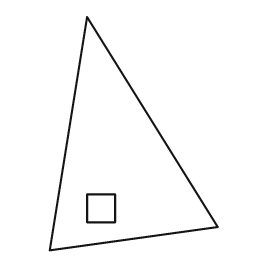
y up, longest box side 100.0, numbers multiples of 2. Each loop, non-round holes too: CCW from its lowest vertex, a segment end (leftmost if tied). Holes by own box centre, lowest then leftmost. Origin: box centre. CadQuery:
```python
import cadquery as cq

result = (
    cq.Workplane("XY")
    .moveTo(-36.0, -50.0)
    .lineTo(36.0, -40.0)
    .lineTo(-20.0, 50.0)
    .close()
    .moveTo(-20.0, -38.0)
    .lineTo(-8.0, -38.0)
    .lineTo(-8.0, -26.0)
    .lineTo(-20.0, -26.0)
    .close()
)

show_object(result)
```